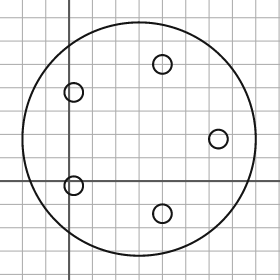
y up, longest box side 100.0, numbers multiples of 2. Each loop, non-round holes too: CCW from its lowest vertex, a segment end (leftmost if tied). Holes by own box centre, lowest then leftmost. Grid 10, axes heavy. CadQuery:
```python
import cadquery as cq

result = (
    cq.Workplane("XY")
    .moveTo(30.0, 18.0)
    .circle(50.0)
    .moveTo(40.0, -14.0)
    .circle(4.0)
    .moveTo(2.0, -2.0)
    .circle(4.0)
    .moveTo(64.0, 18.0)
    .circle(4.0)
    .moveTo(2.0, 38.0)
    .circle(4.0)
    .moveTo(40.0, 50.0)
    .circle(4.0)
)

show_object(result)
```